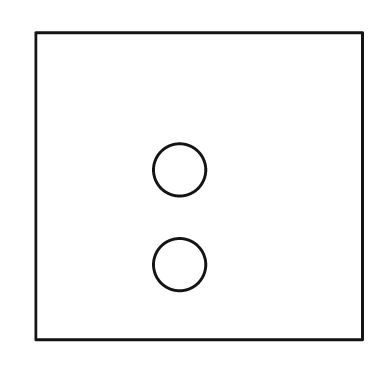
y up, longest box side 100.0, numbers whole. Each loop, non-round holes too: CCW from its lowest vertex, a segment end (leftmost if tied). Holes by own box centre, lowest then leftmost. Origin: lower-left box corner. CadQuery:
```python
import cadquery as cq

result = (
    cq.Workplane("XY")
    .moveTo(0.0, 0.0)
    .lineTo(100.0, 0.0)
    .lineTo(100.0, 94.0)
    .lineTo(0.0, 94.0)
    .close()
    .moveTo(44.0, 23.0)
    .circle(8.0)
    .moveTo(44.0, 52.0)
    .circle(8.0)
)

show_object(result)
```